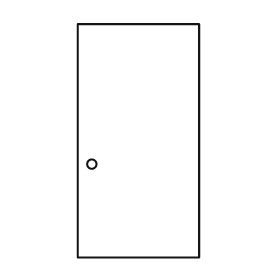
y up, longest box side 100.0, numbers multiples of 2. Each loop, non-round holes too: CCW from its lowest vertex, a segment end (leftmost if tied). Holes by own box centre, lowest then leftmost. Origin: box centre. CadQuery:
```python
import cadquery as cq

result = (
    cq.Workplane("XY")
    .moveTo(-26.0, -50.0)
    .lineTo(26.0, -50.0)
    .lineTo(26.0, 50.0)
    .lineTo(-26.0, 50.0)
    .close()
    .moveTo(-20.0, -10.0)
    .circle(2.0)
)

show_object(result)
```